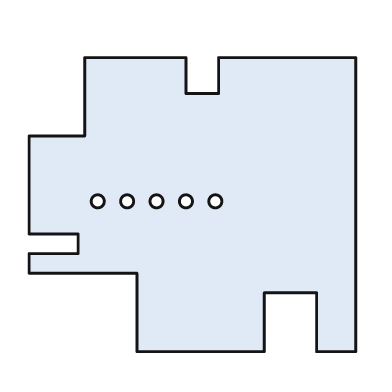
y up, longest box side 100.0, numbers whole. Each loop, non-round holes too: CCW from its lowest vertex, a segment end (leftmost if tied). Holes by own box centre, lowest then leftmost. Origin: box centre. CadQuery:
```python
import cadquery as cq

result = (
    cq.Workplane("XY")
    .moveTo(-17.0, -45.0)
    .lineTo(22.0, -45.0)
    .lineTo(22.0, -27.0)
    .lineTo(38.0, -27.0)
    .lineTo(38.0, -45.0)
    .lineTo(50.0, -45.0)
    .lineTo(50.0, 45.0)
    .lineTo(8.0, 45.0)
    .lineTo(8.0, 34.0)
    .lineTo(-2.0, 34.0)
    .lineTo(-2.0, 45.0)
    .lineTo(-33.0, 45.0)
    .lineTo(-33.0, 21.0)
    .lineTo(-50.0, 21.0)
    .lineTo(-50.0, -9.0)
    .lineTo(-35.0, -9.0)
    .lineTo(-35.0, -15.0)
    .lineTo(-50.0, -15.0)
    .lineTo(-50.0, -21.0)
    .lineTo(-17.0, -21.0)
    .close()
    .moveTo(-29.0, 1.0)
    .circle(2.0)
    .moveTo(-20.0, 1.0)
    .circle(2.0)
    .moveTo(-11.0, 1.0)
    .circle(2.0)
    .moveTo(-2.0, 1.0)
    .circle(2.0)
    .moveTo(7.0, 1.0)
    .circle(2.0)
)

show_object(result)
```